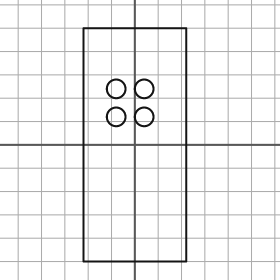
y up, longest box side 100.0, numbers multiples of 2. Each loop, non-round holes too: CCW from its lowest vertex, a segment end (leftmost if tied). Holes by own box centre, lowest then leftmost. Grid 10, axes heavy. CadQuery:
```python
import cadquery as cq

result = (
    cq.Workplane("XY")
    .moveTo(-22.0, -50.0)
    .lineTo(22.0, -50.0)
    .lineTo(22.0, 50.0)
    .lineTo(-22.0, 50.0)
    .close()
    .moveTo(-8.0, 12.0)
    .circle(4.0)
    .moveTo(4.0, 12.0)
    .circle(4.0)
    .moveTo(-8.0, 24.0)
    .circle(4.0)
    .moveTo(4.0, 24.0)
    .circle(4.0)
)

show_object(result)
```